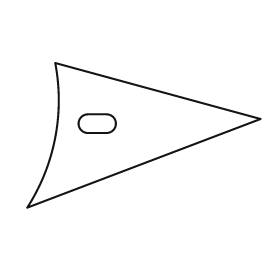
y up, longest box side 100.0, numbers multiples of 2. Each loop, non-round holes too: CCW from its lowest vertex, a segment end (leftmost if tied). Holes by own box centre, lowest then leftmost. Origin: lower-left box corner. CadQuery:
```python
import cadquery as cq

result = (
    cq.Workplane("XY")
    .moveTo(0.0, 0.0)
    .lineTo(100.0, 38.0)
    .lineTo(12.0, 62.0)
    .threePointArc((12.0, 30.0), (0.0, 0.0))
    .close()
    .moveTo(26.0, 32.0)
    .lineTo(34.0, 32.0)
    .threePointArc((38.0, 36.0), (34.0, 40.0))
    .lineTo(26.0, 40.0)
    .threePointArc((22.0, 36.0), (26.0, 32.0))
    .close()
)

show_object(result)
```